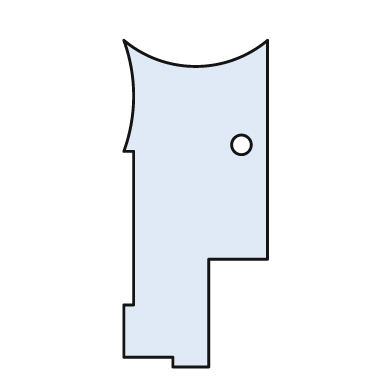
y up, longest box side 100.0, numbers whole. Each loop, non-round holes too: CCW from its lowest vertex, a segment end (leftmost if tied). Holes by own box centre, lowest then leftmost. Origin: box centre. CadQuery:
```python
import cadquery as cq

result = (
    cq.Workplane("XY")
    .moveTo(-7.0, -50.0)
    .lineTo(4.0, -50.0)
    .lineTo(4.0, -17.0)
    .lineTo(22.0, -17.0)
    .lineTo(22.0, 50.0)
    .threePointArc((0.0, 42.0), (-22.0, 50.0))
    .threePointArc((-19.0, 33.0), (-22.0, 16.0))
    .lineTo(-19.0, 16.0)
    .lineTo(-19.0, -31.0)
    .lineTo(-22.0, -31.0)
    .lineTo(-22.0, -47.0)
    .lineTo(-7.0, -47.0)
    .close()
    .moveTo(14.0, 18.0)
    .circle(3.0)
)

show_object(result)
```